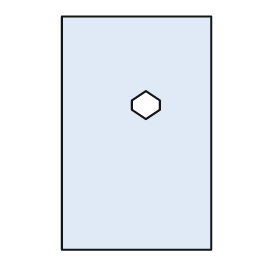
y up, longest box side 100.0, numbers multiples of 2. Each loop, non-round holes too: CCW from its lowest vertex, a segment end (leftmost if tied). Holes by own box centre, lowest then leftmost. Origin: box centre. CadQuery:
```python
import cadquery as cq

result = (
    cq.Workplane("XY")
    .moveTo(-32.0, -50.0)
    .lineTo(32.0, -50.0)
    .lineTo(32.0, 50.0)
    .lineTo(-32.0, 50.0)
    .close()
    .moveTo(4.0, 6.0)
    .lineTo(10.0, 10.0)
    .lineTo(10.0, 14.0)
    .lineTo(4.0, 18.0)
    .lineTo(-2.0, 14.0)
    .lineTo(-2.0, 10.0)
    .close()
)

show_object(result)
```